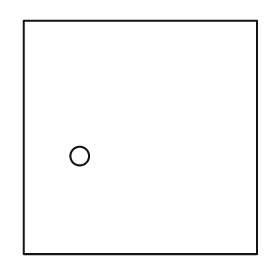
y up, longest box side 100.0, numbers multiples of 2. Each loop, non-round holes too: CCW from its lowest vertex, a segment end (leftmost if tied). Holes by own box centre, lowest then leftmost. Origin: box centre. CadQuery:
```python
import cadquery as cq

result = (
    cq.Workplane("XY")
    .moveTo(-50.0, -50.0)
    .lineTo(50.0, -50.0)
    .lineTo(50.0, 50.0)
    .lineTo(-50.0, 50.0)
    .close()
    .moveTo(-26.0, -8.0)
    .circle(4.0)
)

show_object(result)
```